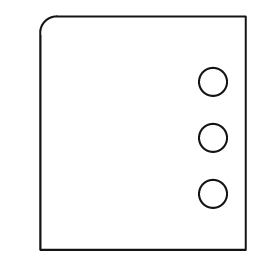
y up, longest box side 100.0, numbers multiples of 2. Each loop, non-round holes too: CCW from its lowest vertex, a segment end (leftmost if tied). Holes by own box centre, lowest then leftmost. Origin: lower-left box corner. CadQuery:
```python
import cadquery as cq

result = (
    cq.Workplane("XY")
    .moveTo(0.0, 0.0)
    .lineTo(88.0, 0.0)
    .lineTo(88.0, 100.0)
    .lineTo(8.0, 100.0)
    .threePointArc((2.0, 98.0), (0.0, 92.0))
    .close()
    .moveTo(74.0, 24.0)
    .circle(6.0)
    .moveTo(74.0, 48.0)
    .circle(6.0)
    .moveTo(74.0, 72.0)
    .circle(6.0)
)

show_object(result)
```